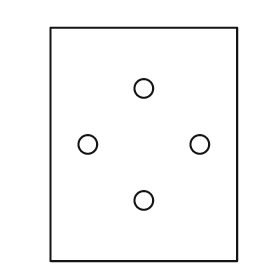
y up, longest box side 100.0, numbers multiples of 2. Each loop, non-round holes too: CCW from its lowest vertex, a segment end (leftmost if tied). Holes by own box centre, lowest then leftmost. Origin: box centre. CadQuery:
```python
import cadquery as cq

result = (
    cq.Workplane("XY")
    .moveTo(-40.0, -50.0)
    .lineTo(40.0, -50.0)
    .lineTo(40.0, 50.0)
    .lineTo(-40.0, 50.0)
    .close()
    .moveTo(0.0, -24.0)
    .circle(4.0)
    .moveTo(-24.0, 0.0)
    .circle(4.0)
    .moveTo(24.0, 0.0)
    .circle(4.0)
    .moveTo(0.0, 24.0)
    .circle(4.0)
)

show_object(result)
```